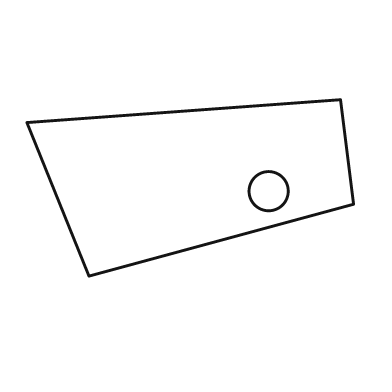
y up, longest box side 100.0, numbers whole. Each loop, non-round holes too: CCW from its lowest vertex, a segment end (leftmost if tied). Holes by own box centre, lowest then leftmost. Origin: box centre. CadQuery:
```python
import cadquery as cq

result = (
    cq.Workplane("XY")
    .moveTo(-31.0, -27.0)
    .lineTo(50.0, -5.0)
    .lineTo(46.0, 27.0)
    .lineTo(-50.0, 20.0)
    .close()
    .moveTo(24.0, -1.0)
    .circle(6.0)
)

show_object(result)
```